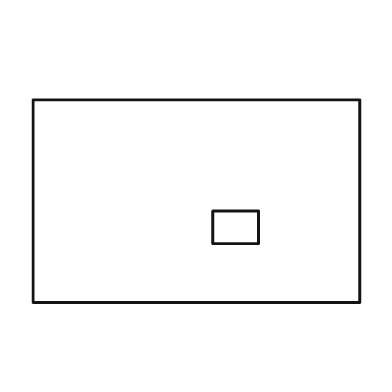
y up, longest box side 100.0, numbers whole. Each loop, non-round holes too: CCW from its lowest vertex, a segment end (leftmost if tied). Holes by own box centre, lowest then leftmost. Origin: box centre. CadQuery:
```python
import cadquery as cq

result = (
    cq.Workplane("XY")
    .moveTo(-50.0, -31.0)
    .lineTo(50.0, -31.0)
    .lineTo(50.0, 31.0)
    .lineTo(-50.0, 31.0)
    .close()
    .moveTo(5.0, -13.0)
    .lineTo(19.0, -13.0)
    .lineTo(19.0, -3.0)
    .lineTo(5.0, -3.0)
    .close()
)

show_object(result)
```